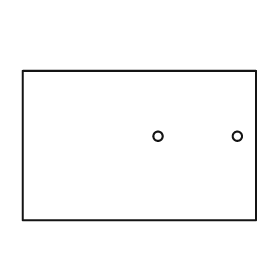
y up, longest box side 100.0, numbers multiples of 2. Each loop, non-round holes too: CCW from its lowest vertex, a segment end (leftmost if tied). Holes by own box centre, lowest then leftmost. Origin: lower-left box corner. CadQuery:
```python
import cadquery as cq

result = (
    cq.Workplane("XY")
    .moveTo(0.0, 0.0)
    .lineTo(100.0, 0.0)
    .lineTo(100.0, 64.0)
    .lineTo(0.0, 64.0)
    .close()
    .moveTo(58.0, 36.0)
    .circle(2.0)
    .moveTo(92.0, 36.0)
    .circle(2.0)
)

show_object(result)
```